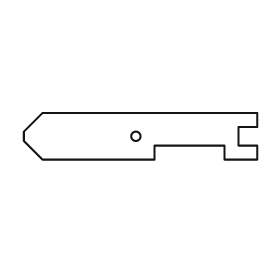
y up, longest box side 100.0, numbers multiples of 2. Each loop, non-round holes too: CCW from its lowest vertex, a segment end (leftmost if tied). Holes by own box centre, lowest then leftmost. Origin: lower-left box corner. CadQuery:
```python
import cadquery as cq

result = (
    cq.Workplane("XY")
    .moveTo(8.0, 0.0)
    .lineTo(56.0, 0.0)
    .lineTo(56.0, 6.0)
    .lineTo(86.0, 6.0)
    .lineTo(86.0, 0.0)
    .lineTo(100.0, 0.0)
    .lineTo(100.0, 6.0)
    .lineTo(92.0, 6.0)
    .lineTo(92.0, 14.0)
    .lineTo(100.0, 14.0)
    .lineTo(100.0, 20.0)
    .lineTo(8.0, 20.0)
    .lineTo(0.0, 12.0)
    .lineTo(0.0, 8.0)
    .close()
    .moveTo(48.0, 10.0)
    .circle(2.0)
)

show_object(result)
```